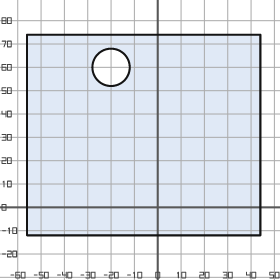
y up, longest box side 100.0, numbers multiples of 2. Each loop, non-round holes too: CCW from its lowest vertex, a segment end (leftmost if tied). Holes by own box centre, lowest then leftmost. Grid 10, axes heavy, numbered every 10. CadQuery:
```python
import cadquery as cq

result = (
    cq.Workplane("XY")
    .moveTo(-56.0, -12.0)
    .lineTo(44.0, -12.0)
    .lineTo(44.0, 74.0)
    .lineTo(-56.0, 74.0)
    .close()
    .moveTo(-20.0, 60.0)
    .circle(8.0)
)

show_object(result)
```